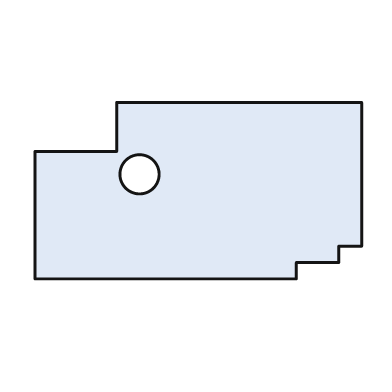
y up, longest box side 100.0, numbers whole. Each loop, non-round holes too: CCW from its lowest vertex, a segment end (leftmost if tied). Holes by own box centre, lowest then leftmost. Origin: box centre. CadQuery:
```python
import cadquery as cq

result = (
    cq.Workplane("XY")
    .moveTo(-50.0, -27.0)
    .lineTo(30.0, -27.0)
    .lineTo(30.0, -22.0)
    .lineTo(43.0, -22.0)
    .lineTo(43.0, -17.0)
    .lineTo(50.0, -17.0)
    .lineTo(50.0, 27.0)
    .lineTo(-25.0, 27.0)
    .lineTo(-25.0, 12.0)
    .lineTo(-50.0, 12.0)
    .close()
    .moveTo(-18.0, 5.0)
    .circle(6.0)
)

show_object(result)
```